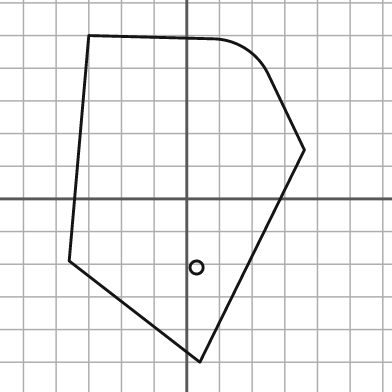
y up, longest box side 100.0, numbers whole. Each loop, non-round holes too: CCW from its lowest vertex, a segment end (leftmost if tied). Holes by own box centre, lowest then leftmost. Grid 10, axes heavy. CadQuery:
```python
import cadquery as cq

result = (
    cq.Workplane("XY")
    .moveTo(4.0, -50.0)
    .lineTo(36.0, 15.0)
    .lineTo(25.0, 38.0)
    .threePointArc((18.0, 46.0), (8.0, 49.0))
    .lineTo(-30.0, 50.0)
    .lineTo(-36.0, -19.0)
    .close()
    .moveTo(3.0, -21.0)
    .circle(2.0)
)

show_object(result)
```